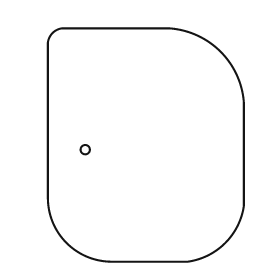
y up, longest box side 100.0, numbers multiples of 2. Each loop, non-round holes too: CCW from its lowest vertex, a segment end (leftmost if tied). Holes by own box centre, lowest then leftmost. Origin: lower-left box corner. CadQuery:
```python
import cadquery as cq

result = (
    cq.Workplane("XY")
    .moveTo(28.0, 0.0)
    .lineTo(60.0, 0.0)
    .threePointArc((76.0, 8.0), (84.0, 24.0))
    .lineTo(84.0, 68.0)
    .threePointArc((74.0, 90.0), (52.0, 100.0))
    .lineTo(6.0, 100.0)
    .threePointArc((2.0, 98.0), (0.0, 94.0))
    .lineTo(0.0, 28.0)
    .threePointArc((8.0, 8.0), (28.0, 0.0))
    .close()
    .moveTo(16.0, 48.0)
    .circle(2.0)
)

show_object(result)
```